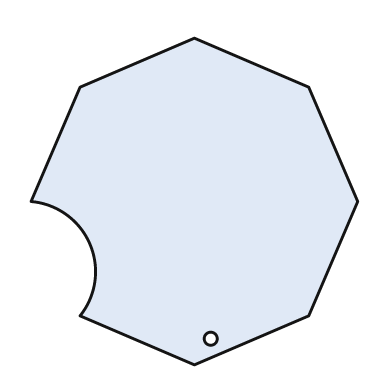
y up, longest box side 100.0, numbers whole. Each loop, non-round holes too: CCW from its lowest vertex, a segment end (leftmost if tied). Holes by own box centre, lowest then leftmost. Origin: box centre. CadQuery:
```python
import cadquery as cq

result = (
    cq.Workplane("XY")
    .moveTo(0.0, -50.0)
    .lineTo(35.0, -35.0)
    .lineTo(50.0, 0.0)
    .lineTo(35.0, 35.0)
    .lineTo(0.0, 50.0)
    .lineTo(-35.0, 35.0)
    .lineTo(-50.0, 0.0)
    .threePointArc((-32.0, -13.0), (-35.0, -35.0))
    .close()
    .moveTo(5.0, -42.0)
    .circle(2.0)
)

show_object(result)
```